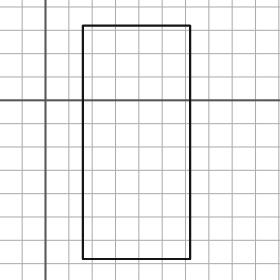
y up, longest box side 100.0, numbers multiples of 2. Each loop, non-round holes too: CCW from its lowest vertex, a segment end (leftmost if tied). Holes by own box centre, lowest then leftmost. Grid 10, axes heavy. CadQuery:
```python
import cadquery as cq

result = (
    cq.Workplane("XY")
    .moveTo(16.0, -68.0)
    .lineTo(62.0, -68.0)
    .lineTo(62.0, 32.0)
    .lineTo(16.0, 32.0)
    .close()
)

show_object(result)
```